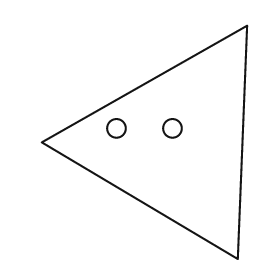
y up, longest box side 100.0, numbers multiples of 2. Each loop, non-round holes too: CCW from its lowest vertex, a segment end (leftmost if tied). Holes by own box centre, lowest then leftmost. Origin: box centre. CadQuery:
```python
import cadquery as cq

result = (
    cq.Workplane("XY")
    .moveTo(40.0, -50.0)
    .lineTo(44.0, 50.0)
    .lineTo(-44.0, 0.0)
    .close()
    .moveTo(-12.0, 6.0)
    .circle(4.0)
    .moveTo(12.0, 6.0)
    .circle(4.0)
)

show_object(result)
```